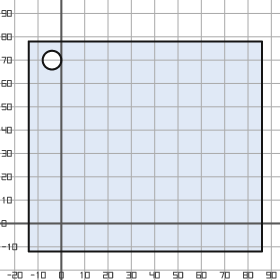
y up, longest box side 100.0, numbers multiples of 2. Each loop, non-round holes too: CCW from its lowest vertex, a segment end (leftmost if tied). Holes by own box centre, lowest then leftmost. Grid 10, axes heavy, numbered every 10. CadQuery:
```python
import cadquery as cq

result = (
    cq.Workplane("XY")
    .moveTo(-14.0, -12.0)
    .lineTo(86.0, -12.0)
    .lineTo(86.0, 78.0)
    .lineTo(-14.0, 78.0)
    .close()
    .moveTo(-4.0, 70.0)
    .circle(4.0)
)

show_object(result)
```